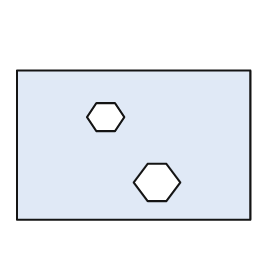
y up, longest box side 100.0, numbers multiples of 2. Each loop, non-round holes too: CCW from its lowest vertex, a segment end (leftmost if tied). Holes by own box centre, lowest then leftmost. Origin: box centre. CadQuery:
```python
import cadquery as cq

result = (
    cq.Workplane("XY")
    .moveTo(-50.0, -32.0)
    .lineTo(50.0, -32.0)
    .lineTo(50.0, 32.0)
    .lineTo(-50.0, 32.0)
    .close()
    .moveTo(6.0, -24.0)
    .lineTo(14.0, -24.0)
    .lineTo(20.0, -16.0)
    .lineTo(14.0, -8.0)
    .lineTo(6.0, -8.0)
    .lineTo(0.0, -16.0)
    .close()
    .moveTo(-16.0, 6.0)
    .lineTo(-8.0, 6.0)
    .lineTo(-4.0, 12.0)
    .lineTo(-8.0, 18.0)
    .lineTo(-16.0, 18.0)
    .lineTo(-20.0, 12.0)
    .close()
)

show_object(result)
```